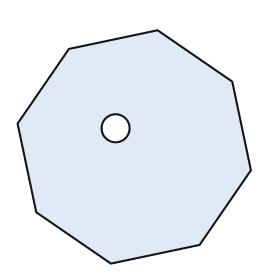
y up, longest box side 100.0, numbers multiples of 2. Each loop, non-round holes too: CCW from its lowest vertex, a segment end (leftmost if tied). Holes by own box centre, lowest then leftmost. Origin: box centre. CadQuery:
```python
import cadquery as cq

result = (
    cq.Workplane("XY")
    .moveTo(-10.0, -50.0)
    .lineTo(28.0, -42.0)
    .lineTo(50.0, -10.0)
    .lineTo(42.0, 28.0)
    .lineTo(10.0, 50.0)
    .lineTo(-28.0, 42.0)
    .lineTo(-50.0, 10.0)
    .lineTo(-42.0, -28.0)
    .close()
    .moveTo(-8.0, 8.0)
    .circle(6.0)
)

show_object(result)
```